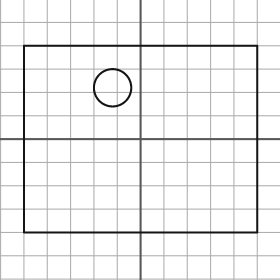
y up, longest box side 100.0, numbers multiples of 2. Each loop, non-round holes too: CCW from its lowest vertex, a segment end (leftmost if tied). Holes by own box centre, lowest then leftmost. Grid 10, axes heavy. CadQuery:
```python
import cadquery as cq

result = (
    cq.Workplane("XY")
    .moveTo(-50.0, -40.0)
    .lineTo(50.0, -40.0)
    .lineTo(50.0, 40.0)
    .lineTo(-50.0, 40.0)
    .close()
    .moveTo(-12.0, 22.0)
    .circle(8.0)
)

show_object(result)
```